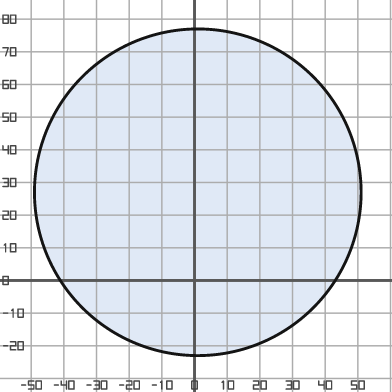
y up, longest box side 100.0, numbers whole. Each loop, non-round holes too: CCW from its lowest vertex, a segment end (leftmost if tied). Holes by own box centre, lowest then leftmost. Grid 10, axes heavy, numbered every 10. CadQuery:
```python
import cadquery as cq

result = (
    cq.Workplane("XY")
    .moveTo(1.0, 27.0)
    .circle(50.0)
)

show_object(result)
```